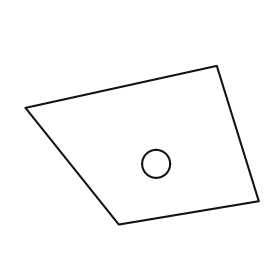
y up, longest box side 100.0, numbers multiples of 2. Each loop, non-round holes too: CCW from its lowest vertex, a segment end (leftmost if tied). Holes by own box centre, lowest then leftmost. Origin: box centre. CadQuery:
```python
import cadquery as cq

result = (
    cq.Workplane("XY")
    .moveTo(-10.0, -34.0)
    .lineTo(50.0, -24.0)
    .lineTo(32.0, 34.0)
    .lineTo(-50.0, 16.0)
    .close()
    .moveTo(6.0, -8.0)
    .circle(6.0)
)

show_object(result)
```